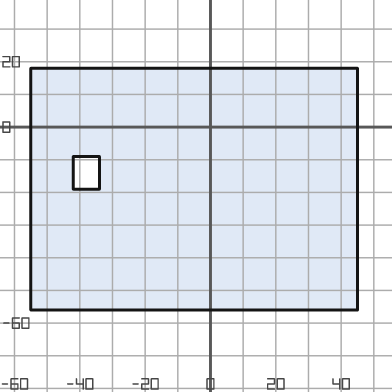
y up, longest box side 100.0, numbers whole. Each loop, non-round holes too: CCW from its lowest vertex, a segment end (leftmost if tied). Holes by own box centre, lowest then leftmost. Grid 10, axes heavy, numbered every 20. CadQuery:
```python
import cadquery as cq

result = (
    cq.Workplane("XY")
    .moveTo(-55.0, -56.0)
    .lineTo(45.0, -56.0)
    .lineTo(45.0, 18.0)
    .lineTo(-55.0, 18.0)
    .close()
    .moveTo(-42.0, -19.0)
    .lineTo(-34.0, -19.0)
    .lineTo(-34.0, -9.0)
    .lineTo(-42.0, -9.0)
    .close()
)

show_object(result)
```